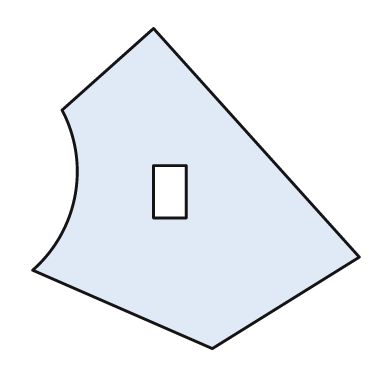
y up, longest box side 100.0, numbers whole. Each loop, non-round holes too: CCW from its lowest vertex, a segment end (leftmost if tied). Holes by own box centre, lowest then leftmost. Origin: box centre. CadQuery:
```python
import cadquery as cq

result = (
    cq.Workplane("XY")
    .moveTo(5.0, -49.0)
    .lineTo(50.0, -21.0)
    .lineTo(-13.0, 49.0)
    .lineTo(-41.0, 24.0)
    .threePointArc((-37.0, -2.0), (-50.0, -25.0))
    .close()
    .moveTo(-13.0, -9.0)
    .lineTo(-3.0, -9.0)
    .lineTo(-3.0, 7.0)
    .lineTo(-13.0, 7.0)
    .close()
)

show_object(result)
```